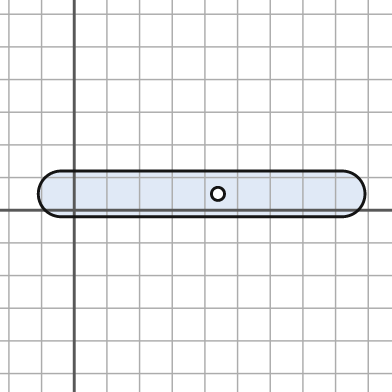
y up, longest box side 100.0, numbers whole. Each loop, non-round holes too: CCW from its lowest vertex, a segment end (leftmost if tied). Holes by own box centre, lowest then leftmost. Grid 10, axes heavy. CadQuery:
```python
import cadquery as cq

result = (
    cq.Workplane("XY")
    .moveTo(-4.0, -2.0)
    .lineTo(82.0, -2.0)
    .threePointArc((89.0, 5.0), (82.0, 12.0))
    .lineTo(-4.0, 12.0)
    .threePointArc((-11.0, 5.0), (-4.0, -2.0))
    .close()
    .moveTo(44.0, 5.0)
    .circle(2.0)
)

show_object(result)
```